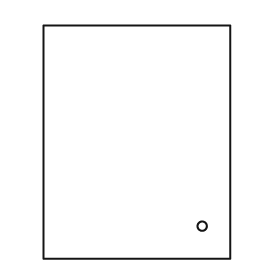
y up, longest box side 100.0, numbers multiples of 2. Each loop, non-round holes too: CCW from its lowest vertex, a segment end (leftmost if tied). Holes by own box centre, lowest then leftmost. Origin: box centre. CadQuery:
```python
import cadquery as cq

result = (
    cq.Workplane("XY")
    .moveTo(-40.0, -50.0)
    .lineTo(40.0, -50.0)
    .lineTo(40.0, 50.0)
    .lineTo(-40.0, 50.0)
    .close()
    .moveTo(28.0, -36.0)
    .circle(2.0)
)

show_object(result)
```